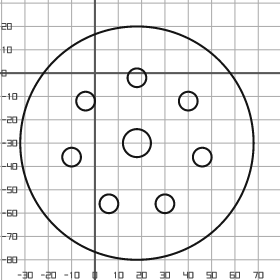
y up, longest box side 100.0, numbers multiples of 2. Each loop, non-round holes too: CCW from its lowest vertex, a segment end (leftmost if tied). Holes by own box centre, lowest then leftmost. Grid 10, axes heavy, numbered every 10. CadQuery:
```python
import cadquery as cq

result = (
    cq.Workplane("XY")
    .moveTo(18.0, -30.0)
    .circle(50.0)
    .moveTo(6.0, -56.0)
    .circle(4.0)
    .moveTo(30.0, -56.0)
    .circle(4.0)
    .moveTo(-10.0, -36.0)
    .circle(4.0)
    .moveTo(46.0, -36.0)
    .circle(4.0)
    .moveTo(18.0, -30.0)
    .circle(6.0)
    .moveTo(-4.0, -12.0)
    .circle(4.0)
    .moveTo(40.0, -12.0)
    .circle(4.0)
    .moveTo(18.0, -2.0)
    .circle(4.0)
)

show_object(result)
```